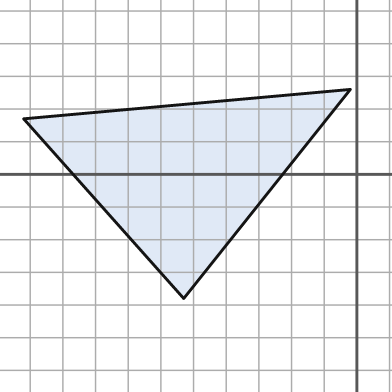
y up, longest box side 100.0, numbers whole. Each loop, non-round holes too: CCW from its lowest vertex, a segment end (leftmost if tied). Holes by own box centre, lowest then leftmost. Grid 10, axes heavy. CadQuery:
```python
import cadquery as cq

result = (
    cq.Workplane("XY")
    .moveTo(-53.0, -38.0)
    .lineTo(-2.0, 26.0)
    .lineTo(-102.0, 17.0)
    .close()
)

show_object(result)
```